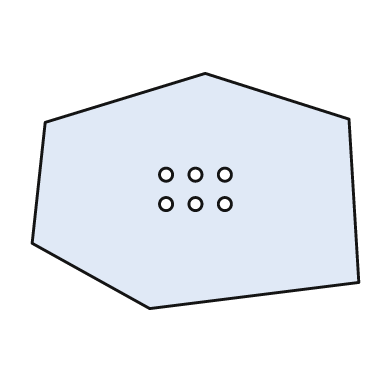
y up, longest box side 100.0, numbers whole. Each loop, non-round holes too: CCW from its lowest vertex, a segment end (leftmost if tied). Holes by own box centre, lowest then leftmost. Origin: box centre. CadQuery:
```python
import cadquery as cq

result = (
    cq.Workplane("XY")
    .moveTo(-14.0, -36.0)
    .lineTo(50.0, -28.0)
    .lineTo(47.0, 22.0)
    .lineTo(3.0, 36.0)
    .lineTo(-46.0, 21.0)
    .lineTo(-50.0, -16.0)
    .close()
    .moveTo(-9.0, -4.0)
    .circle(2.0)
    .moveTo(0.0, -4.0)
    .circle(2.0)
    .moveTo(9.0, -4.0)
    .circle(2.0)
    .moveTo(-9.0, 5.0)
    .circle(2.0)
    .moveTo(0.0, 5.0)
    .circle(2.0)
    .moveTo(9.0, 5.0)
    .circle(2.0)
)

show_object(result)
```